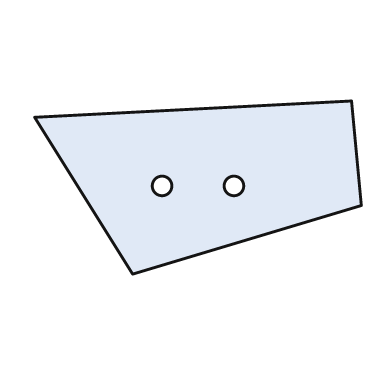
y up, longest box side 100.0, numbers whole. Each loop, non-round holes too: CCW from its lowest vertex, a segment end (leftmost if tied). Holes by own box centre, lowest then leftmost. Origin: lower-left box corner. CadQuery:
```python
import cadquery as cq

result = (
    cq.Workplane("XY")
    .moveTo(30.0, 0.0)
    .lineTo(100.0, 21.0)
    .lineTo(97.0, 53.0)
    .lineTo(0.0, 48.0)
    .close()
    .moveTo(39.0, 27.0)
    .circle(3.0)
    .moveTo(61.0, 27.0)
    .circle(3.0)
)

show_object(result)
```